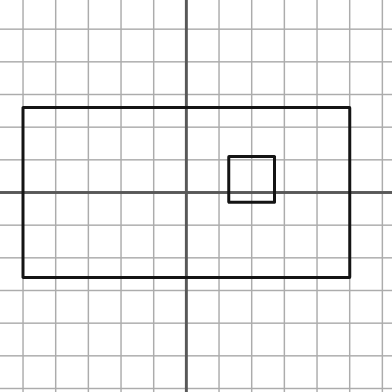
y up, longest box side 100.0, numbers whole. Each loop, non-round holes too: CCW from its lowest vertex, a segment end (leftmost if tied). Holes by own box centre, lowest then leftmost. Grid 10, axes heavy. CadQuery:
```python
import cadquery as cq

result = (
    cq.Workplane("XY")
    .moveTo(-50.0, -26.0)
    .lineTo(50.0, -26.0)
    .lineTo(50.0, 26.0)
    .lineTo(-50.0, 26.0)
    .close()
    .moveTo(13.0, -3.0)
    .lineTo(27.0, -3.0)
    .lineTo(27.0, 11.0)
    .lineTo(13.0, 11.0)
    .close()
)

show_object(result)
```